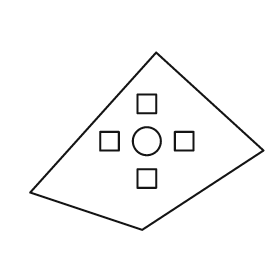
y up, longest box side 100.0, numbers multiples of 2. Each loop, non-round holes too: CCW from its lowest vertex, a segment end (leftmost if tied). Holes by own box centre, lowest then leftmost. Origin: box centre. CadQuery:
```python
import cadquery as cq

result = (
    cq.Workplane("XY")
    .moveTo(-2.0, -38.0)
    .lineTo(50.0, -4.0)
    .lineTo(4.0, 38.0)
    .lineTo(-50.0, -22.0)
    .close()
    .moveTo(-4.0, -20.0)
    .lineTo(4.0, -20.0)
    .lineTo(4.0, -12.0)
    .lineTo(-4.0, -12.0)
    .close()
    .moveTo(-20.0, -4.0)
    .lineTo(-12.0, -4.0)
    .lineTo(-12.0, 4.0)
    .lineTo(-20.0, 4.0)
    .close()
    .moveTo(0.0, 0.0)
    .circle(6.0)
    .moveTo(12.0, -4.0)
    .lineTo(20.0, -4.0)
    .lineTo(20.0, 4.0)
    .lineTo(12.0, 4.0)
    .close()
    .moveTo(-4.0, 12.0)
    .lineTo(4.0, 12.0)
    .lineTo(4.0, 20.0)
    .lineTo(-4.0, 20.0)
    .close()
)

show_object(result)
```